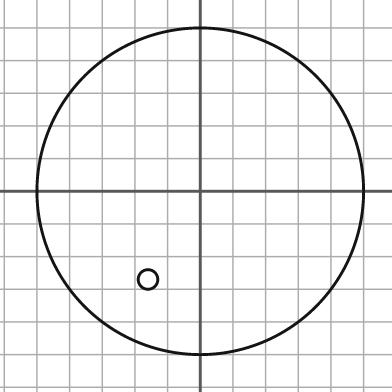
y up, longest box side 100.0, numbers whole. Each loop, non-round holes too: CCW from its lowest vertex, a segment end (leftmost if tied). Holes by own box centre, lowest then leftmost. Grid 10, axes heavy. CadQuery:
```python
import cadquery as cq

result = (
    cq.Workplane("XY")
    .moveTo(0.0, 0.0)
    .circle(50.0)
    .moveTo(-16.0, -27.0)
    .circle(3.0)
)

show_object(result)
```